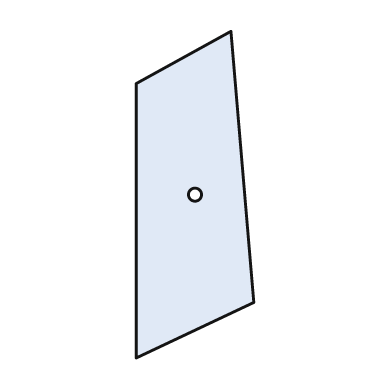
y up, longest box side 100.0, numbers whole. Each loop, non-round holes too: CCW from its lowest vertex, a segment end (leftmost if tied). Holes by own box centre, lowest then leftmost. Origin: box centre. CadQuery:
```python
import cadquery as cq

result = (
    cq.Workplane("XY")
    .moveTo(-18.0, -50.0)
    .lineTo(18.0, -33.0)
    .lineTo(11.0, 50.0)
    .lineTo(-18.0, 34.0)
    .close()
    .moveTo(0.0, 0.0)
    .circle(2.0)
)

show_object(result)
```